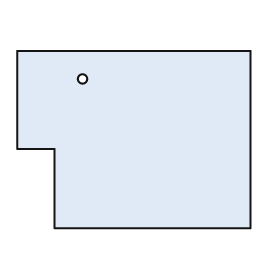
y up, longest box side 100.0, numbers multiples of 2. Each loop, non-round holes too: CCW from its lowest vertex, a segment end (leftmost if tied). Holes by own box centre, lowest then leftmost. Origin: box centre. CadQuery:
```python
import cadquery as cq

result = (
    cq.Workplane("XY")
    .moveTo(-34.0, -38.0)
    .lineTo(50.0, -38.0)
    .lineTo(50.0, 38.0)
    .lineTo(-50.0, 38.0)
    .lineTo(-50.0, -4.0)
    .lineTo(-34.0, -4.0)
    .close()
    .moveTo(-22.0, 26.0)
    .circle(2.0)
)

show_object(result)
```